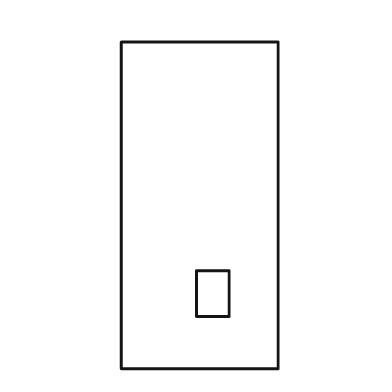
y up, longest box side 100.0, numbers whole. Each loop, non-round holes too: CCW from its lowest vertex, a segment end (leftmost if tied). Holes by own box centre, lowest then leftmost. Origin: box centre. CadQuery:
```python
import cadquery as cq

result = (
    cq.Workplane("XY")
    .moveTo(-24.0, -50.0)
    .lineTo(24.0, -50.0)
    .lineTo(24.0, 50.0)
    .lineTo(-24.0, 50.0)
    .close()
    .moveTo(-1.0, -34.0)
    .lineTo(9.0, -34.0)
    .lineTo(9.0, -20.0)
    .lineTo(-1.0, -20.0)
    .close()
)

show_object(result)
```